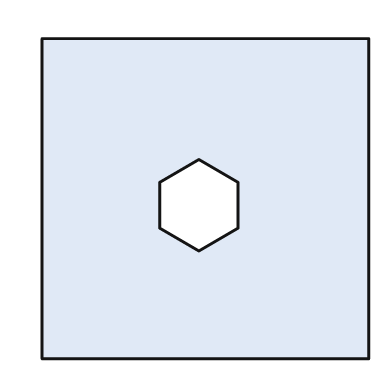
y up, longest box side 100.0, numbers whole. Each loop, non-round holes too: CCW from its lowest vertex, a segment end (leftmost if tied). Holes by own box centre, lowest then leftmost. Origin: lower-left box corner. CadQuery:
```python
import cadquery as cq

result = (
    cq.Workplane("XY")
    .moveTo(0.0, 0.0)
    .lineTo(100.0, 0.0)
    .lineTo(100.0, 98.0)
    .lineTo(0.0, 98.0)
    .close()
    .moveTo(48.0, 33.0)
    .lineTo(60.0, 40.0)
    .lineTo(60.0, 54.0)
    .lineTo(48.0, 61.0)
    .lineTo(36.0, 54.0)
    .lineTo(36.0, 40.0)
    .close()
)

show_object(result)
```